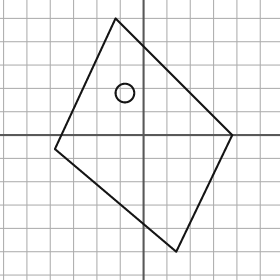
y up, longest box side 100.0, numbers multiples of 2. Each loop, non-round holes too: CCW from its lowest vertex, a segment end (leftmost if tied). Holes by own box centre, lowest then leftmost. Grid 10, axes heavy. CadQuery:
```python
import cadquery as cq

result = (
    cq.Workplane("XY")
    .moveTo(14.0, -50.0)
    .lineTo(38.0, 0.0)
    .lineTo(-12.0, 50.0)
    .lineTo(-38.0, -6.0)
    .close()
    .moveTo(-8.0, 18.0)
    .circle(4.0)
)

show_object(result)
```